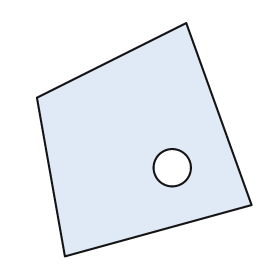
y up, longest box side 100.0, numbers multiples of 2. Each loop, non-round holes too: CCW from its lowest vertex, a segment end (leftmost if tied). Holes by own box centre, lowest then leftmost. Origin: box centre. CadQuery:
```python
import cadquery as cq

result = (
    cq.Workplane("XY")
    .moveTo(-34.0, -50.0)
    .lineTo(46.0, -28.0)
    .lineTo(18.0, 50.0)
    .lineTo(-46.0, 18.0)
    .close()
    .moveTo(12.0, -12.0)
    .circle(8.0)
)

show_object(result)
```